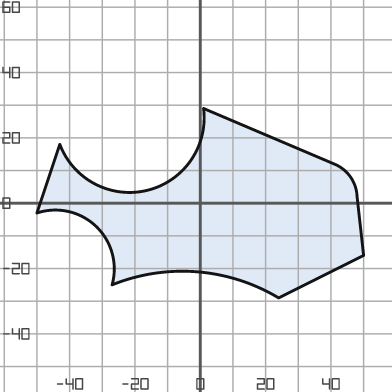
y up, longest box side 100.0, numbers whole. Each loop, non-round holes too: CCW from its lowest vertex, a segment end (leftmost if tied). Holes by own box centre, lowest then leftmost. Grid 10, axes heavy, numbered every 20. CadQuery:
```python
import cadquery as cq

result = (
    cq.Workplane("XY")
    .moveTo(24.0, -29.0)
    .lineTo(50.0, -16.0)
    .lineTo(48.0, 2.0)
    .threePointArc((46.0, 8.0), (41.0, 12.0))
    .lineTo(1.0, 29.0)
    .threePointArc((-16.0, 4.0), (-43.0, 18.0))
    .lineTo(-50.0, -3.0)
    .threePointArc((-32.0, -7.0), (-27.0, -25.0))
    .threePointArc((-1.0, -21.0), (24.0, -29.0))
    .close()
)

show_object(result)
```